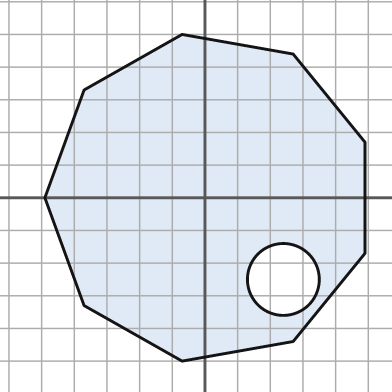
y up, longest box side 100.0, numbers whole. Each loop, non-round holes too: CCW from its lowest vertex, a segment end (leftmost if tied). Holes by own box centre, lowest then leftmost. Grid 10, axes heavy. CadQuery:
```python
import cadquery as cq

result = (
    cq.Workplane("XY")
    .moveTo(-7.0, -50.0)
    .lineTo(27.0, -44.0)
    .lineTo(49.0, -17.0)
    .lineTo(49.0, 17.0)
    .lineTo(27.0, 44.0)
    .lineTo(-7.0, 50.0)
    .lineTo(-37.0, 33.0)
    .lineTo(-49.0, 0.0)
    .lineTo(-37.0, -33.0)
    .close()
    .moveTo(24.0, -25.0)
    .circle(11.0)
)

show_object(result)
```